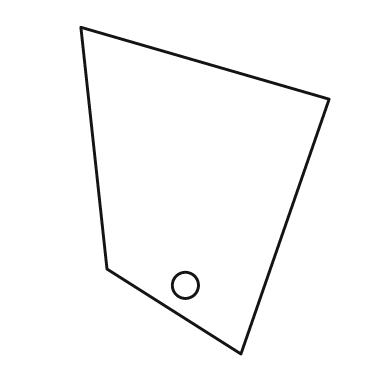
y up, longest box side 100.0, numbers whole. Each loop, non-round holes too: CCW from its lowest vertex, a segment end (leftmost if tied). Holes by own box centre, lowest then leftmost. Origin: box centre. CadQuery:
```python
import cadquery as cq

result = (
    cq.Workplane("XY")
    .moveTo(11.0, -50.0)
    .lineTo(38.0, 28.0)
    .lineTo(-38.0, 50.0)
    .lineTo(-30.0, -24.0)
    .close()
    .moveTo(-6.0, -29.0)
    .circle(4.0)
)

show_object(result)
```